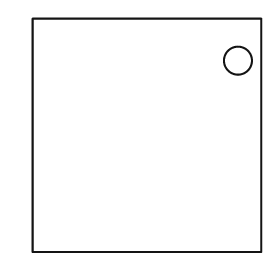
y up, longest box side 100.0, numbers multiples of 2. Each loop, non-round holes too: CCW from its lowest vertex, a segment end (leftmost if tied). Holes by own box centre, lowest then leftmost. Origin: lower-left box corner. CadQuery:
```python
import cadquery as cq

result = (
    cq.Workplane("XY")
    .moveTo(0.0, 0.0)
    .lineTo(98.0, 0.0)
    .lineTo(98.0, 100.0)
    .lineTo(0.0, 100.0)
    .close()
    .moveTo(88.0, 82.0)
    .circle(6.0)
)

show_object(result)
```